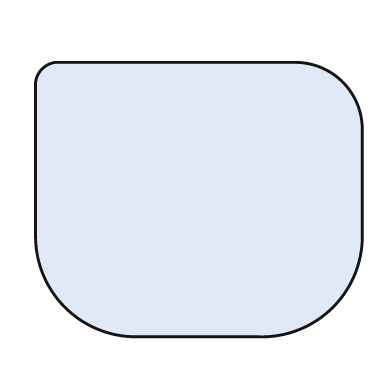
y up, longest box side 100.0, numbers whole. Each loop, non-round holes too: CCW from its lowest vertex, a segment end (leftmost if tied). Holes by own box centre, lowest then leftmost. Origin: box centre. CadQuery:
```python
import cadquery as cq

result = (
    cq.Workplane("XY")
    .moveTo(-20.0, -42.0)
    .lineTo(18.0, -42.0)
    .threePointArc((41.0, -33.0), (50.0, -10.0))
    .lineTo(50.0, 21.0)
    .threePointArc((44.0, 36.0), (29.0, 42.0))
    .lineTo(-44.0, 42.0)
    .threePointArc((-48.0, 40.0), (-50.0, 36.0))
    .lineTo(-50.0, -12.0)
    .threePointArc((-41.0, -33.0), (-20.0, -42.0))
    .close()
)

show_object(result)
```